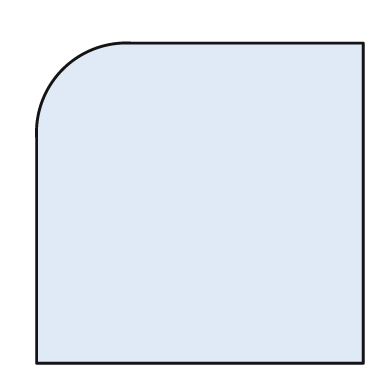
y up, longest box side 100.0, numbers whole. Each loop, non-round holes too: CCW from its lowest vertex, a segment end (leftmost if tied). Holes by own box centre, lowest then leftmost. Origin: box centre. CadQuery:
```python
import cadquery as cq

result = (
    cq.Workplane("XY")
    .moveTo(-50.0, -49.0)
    .lineTo(50.0, -49.0)
    .lineTo(50.0, 49.0)
    .lineTo(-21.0, 49.0)
    .threePointArc((-42.0, 41.0), (-50.0, 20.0))
    .close()
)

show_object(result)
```